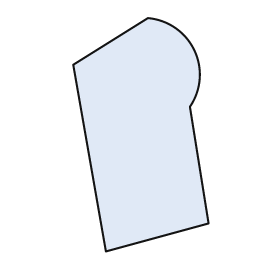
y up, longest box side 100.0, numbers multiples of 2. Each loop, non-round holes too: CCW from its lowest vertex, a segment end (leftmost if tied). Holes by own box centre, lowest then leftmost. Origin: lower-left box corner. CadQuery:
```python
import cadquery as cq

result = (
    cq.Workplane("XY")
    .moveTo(14.0, 0.0)
    .lineTo(58.0, 12.0)
    .lineTo(50.0, 62.0)
    .threePointArc((52.0, 86.0), (32.0, 100.0))
    .lineTo(0.0, 80.0)
    .close()
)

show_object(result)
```